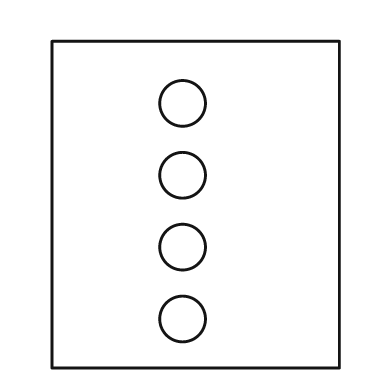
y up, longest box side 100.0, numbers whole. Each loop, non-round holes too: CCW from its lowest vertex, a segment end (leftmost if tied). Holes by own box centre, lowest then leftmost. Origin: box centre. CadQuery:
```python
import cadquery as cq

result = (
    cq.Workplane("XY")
    .moveTo(-44.0, -50.0)
    .lineTo(44.0, -50.0)
    .lineTo(44.0, 50.0)
    .lineTo(-44.0, 50.0)
    .close()
    .moveTo(-4.0, -35.0)
    .circle(7.0)
    .moveTo(-4.0, -13.0)
    .circle(7.0)
    .moveTo(-4.0, 9.0)
    .circle(7.0)
    .moveTo(-4.0, 31.0)
    .circle(7.0)
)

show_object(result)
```